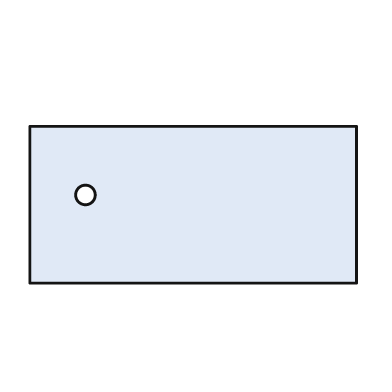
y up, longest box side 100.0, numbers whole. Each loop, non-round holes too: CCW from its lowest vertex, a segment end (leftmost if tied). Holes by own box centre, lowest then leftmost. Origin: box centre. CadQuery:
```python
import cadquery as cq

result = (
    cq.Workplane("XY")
    .moveTo(-50.0, -24.0)
    .lineTo(50.0, -24.0)
    .lineTo(50.0, 24.0)
    .lineTo(-50.0, 24.0)
    .close()
    .moveTo(-33.0, 3.0)
    .circle(3.0)
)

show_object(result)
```